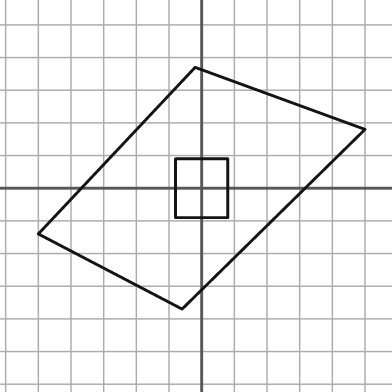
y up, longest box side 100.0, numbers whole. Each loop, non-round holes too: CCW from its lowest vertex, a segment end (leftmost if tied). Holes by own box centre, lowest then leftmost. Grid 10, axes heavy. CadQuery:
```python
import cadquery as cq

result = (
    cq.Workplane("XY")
    .moveTo(-6.0, -37.0)
    .lineTo(50.0, 18.0)
    .lineTo(-2.0, 37.0)
    .lineTo(-50.0, -14.0)
    .close()
    .moveTo(-8.0, -9.0)
    .lineTo(8.0, -9.0)
    .lineTo(8.0, 9.0)
    .lineTo(-8.0, 9.0)
    .close()
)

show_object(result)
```